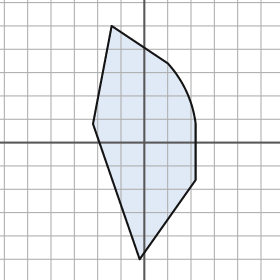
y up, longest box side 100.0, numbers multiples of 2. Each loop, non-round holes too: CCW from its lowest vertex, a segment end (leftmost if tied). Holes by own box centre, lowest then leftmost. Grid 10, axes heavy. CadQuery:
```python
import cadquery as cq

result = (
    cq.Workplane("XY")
    .moveTo(-2.0, -50.0)
    .lineTo(22.0, -16.0)
    .lineTo(22.0, 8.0)
    .threePointArc((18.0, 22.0), (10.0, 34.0))
    .lineTo(-14.0, 50.0)
    .lineTo(-22.0, 8.0)
    .close()
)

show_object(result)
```